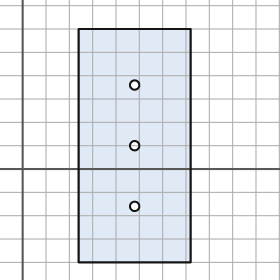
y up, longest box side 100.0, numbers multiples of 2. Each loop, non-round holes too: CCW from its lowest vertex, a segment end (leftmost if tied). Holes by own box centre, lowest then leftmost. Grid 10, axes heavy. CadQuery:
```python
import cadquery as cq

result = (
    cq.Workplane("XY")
    .moveTo(24.0, -40.0)
    .lineTo(72.0, -40.0)
    .lineTo(72.0, 60.0)
    .lineTo(24.0, 60.0)
    .close()
    .moveTo(48.0, -16.0)
    .circle(2.0)
    .moveTo(48.0, 10.0)
    .circle(2.0)
    .moveTo(48.0, 36.0)
    .circle(2.0)
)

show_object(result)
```